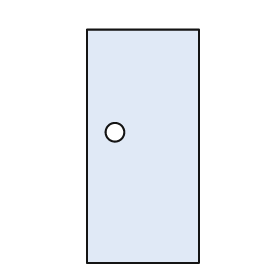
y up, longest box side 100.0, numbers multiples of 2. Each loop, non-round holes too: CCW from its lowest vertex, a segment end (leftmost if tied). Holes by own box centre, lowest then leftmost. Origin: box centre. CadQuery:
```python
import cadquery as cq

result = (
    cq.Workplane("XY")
    .moveTo(-24.0, -50.0)
    .lineTo(24.0, -50.0)
    .lineTo(24.0, 50.0)
    .lineTo(-24.0, 50.0)
    .close()
    .moveTo(-12.0, 6.0)
    .circle(4.0)
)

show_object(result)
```